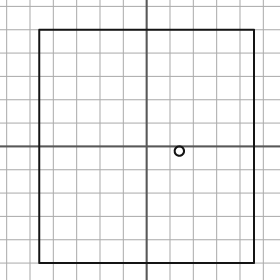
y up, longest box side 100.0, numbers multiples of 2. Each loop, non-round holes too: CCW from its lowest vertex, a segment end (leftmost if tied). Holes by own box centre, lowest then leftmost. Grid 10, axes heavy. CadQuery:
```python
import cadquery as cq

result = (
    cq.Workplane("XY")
    .moveTo(-46.0, -50.0)
    .lineTo(46.0, -50.0)
    .lineTo(46.0, 50.0)
    .lineTo(-46.0, 50.0)
    .close()
    .moveTo(14.0, -2.0)
    .circle(2.0)
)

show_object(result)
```